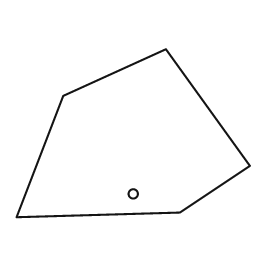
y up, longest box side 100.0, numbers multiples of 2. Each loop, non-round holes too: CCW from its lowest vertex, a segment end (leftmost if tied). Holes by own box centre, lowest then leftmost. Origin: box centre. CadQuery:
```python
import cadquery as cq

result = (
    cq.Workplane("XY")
    .moveTo(-50.0, -36.0)
    .lineTo(20.0, -34.0)
    .lineTo(50.0, -14.0)
    .lineTo(14.0, 36.0)
    .lineTo(-30.0, 16.0)
    .close()
    .moveTo(0.0, -26.0)
    .circle(2.0)
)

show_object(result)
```